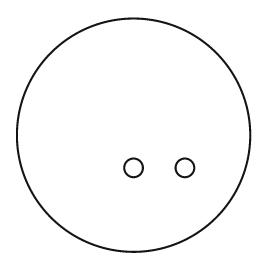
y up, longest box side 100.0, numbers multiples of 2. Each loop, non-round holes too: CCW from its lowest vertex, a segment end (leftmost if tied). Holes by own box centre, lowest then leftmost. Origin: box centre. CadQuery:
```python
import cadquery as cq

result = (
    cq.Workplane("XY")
    .moveTo(0.0, 0.0)
    .circle(50.0)
    .moveTo(0.0, -14.0)
    .circle(4.0)
    .moveTo(22.0, -14.0)
    .circle(4.0)
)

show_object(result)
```